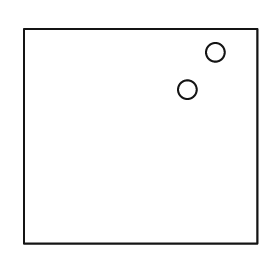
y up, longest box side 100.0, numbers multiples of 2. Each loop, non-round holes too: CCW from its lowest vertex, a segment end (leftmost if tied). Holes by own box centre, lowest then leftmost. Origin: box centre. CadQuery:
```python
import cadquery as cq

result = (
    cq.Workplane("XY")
    .moveTo(-50.0, -46.0)
    .lineTo(50.0, -46.0)
    .lineTo(50.0, 46.0)
    .lineTo(-50.0, 46.0)
    .close()
    .moveTo(20.0, 20.0)
    .circle(4.0)
    .moveTo(32.0, 36.0)
    .circle(4.0)
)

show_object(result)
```